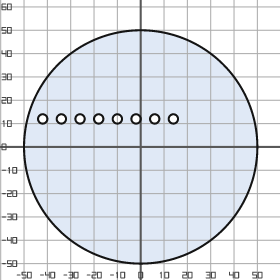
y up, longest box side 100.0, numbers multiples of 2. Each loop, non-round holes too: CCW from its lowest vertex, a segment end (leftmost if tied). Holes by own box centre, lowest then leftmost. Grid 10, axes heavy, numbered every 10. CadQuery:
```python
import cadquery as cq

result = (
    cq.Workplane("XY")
    .moveTo(0.0, 0.0)
    .circle(50.0)
    .moveTo(-42.0, 12.0)
    .circle(2.0)
    .moveTo(-34.0, 12.0)
    .circle(2.0)
    .moveTo(-26.0, 12.0)
    .circle(2.0)
    .moveTo(-18.0, 12.0)
    .circle(2.0)
    .moveTo(-10.0, 12.0)
    .circle(2.0)
    .moveTo(-2.0, 12.0)
    .circle(2.0)
    .moveTo(6.0, 12.0)
    .circle(2.0)
    .moveTo(14.0, 12.0)
    .circle(2.0)
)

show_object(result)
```